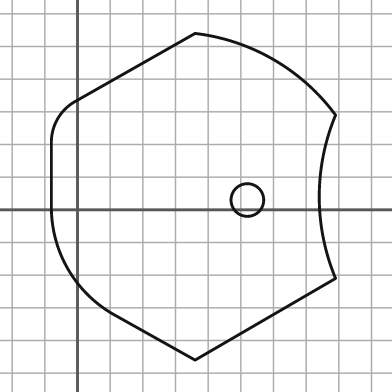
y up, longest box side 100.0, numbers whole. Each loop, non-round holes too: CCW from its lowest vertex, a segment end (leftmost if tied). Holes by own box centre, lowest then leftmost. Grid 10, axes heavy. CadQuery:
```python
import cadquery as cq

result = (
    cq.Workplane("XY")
    .moveTo(36.0, -46.0)
    .lineTo(79.0, -21.0)
    .threePointArc((74.0, 4.0), (79.0, 29.0))
    .threePointArc((60.0, 46.0), (36.0, 54.0))
    .lineTo(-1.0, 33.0)
    .threePointArc((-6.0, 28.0), (-8.0, 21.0))
    .lineTo(-8.0, 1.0)
    .threePointArc((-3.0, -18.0), (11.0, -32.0))
    .close()
    .moveTo(52.0, 3.0)
    .circle(5.0)
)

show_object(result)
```